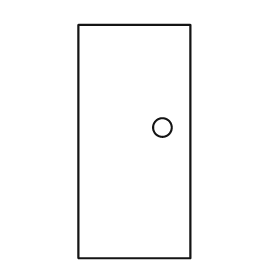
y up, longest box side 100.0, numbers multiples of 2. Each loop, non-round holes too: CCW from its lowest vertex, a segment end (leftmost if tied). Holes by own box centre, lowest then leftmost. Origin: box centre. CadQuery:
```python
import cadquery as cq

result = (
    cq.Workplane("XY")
    .moveTo(-24.0, -50.0)
    .lineTo(24.0, -50.0)
    .lineTo(24.0, 50.0)
    .lineTo(-24.0, 50.0)
    .close()
    .moveTo(12.0, 6.0)
    .circle(4.0)
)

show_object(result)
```